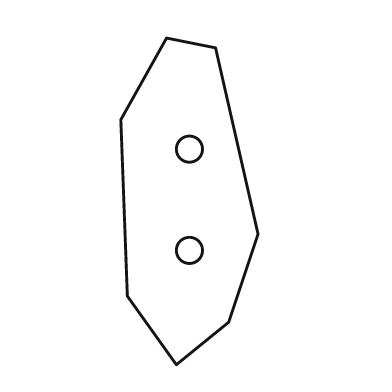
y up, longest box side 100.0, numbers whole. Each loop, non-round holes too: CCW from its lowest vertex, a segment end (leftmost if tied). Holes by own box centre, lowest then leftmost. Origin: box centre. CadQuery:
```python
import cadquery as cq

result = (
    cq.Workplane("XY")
    .moveTo(-4.0, -50.0)
    .lineTo(12.0, -37.0)
    .lineTo(21.0, -10.0)
    .lineTo(8.0, 47.0)
    .lineTo(-7.0, 50.0)
    .lineTo(-21.0, 25.0)
    .lineTo(-19.0, -29.0)
    .close()
    .moveTo(0.0, -15.0)
    .circle(4.0)
    .moveTo(0.0, 16.0)
    .circle(4.0)
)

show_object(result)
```